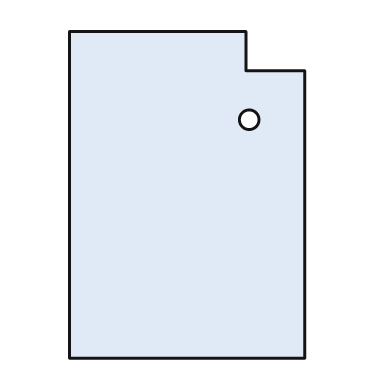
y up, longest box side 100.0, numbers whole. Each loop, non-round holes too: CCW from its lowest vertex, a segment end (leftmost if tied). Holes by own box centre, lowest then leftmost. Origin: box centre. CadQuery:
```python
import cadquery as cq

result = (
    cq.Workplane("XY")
    .moveTo(-36.0, -50.0)
    .lineTo(36.0, -50.0)
    .lineTo(36.0, 38.0)
    .lineTo(18.0, 38.0)
    .lineTo(18.0, 50.0)
    .lineTo(-36.0, 50.0)
    .close()
    .moveTo(19.0, 23.0)
    .circle(3.0)
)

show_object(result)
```